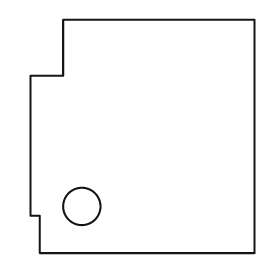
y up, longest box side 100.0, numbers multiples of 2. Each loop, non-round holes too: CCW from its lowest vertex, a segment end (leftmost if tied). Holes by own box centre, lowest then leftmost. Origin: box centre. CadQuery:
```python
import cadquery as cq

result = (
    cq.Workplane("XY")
    .moveTo(-44.0, -50.0)
    .lineTo(48.0, -50.0)
    .lineTo(48.0, 50.0)
    .lineTo(-34.0, 50.0)
    .lineTo(-34.0, 26.0)
    .lineTo(-48.0, 26.0)
    .lineTo(-48.0, -34.0)
    .lineTo(-44.0, -34.0)
    .close()
    .moveTo(-26.0, -30.0)
    .circle(8.0)
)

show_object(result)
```